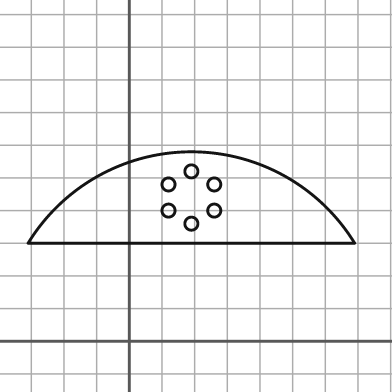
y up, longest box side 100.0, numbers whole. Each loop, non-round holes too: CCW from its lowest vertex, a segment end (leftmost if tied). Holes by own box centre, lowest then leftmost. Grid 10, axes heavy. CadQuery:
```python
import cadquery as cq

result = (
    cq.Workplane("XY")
    .moveTo(-31.0, 30.0)
    .lineTo(69.0, 30.0)
    .threePointArc((19.0, 58.0), (-31.0, 30.0))
    .close()
    .moveTo(19.0, 36.0)
    .circle(2.0)
    .moveTo(12.0, 40.0)
    .circle(2.0)
    .moveTo(26.0, 40.0)
    .circle(2.0)
    .moveTo(12.0, 48.0)
    .circle(2.0)
    .moveTo(26.0, 48.0)
    .circle(2.0)
    .moveTo(19.0, 52.0)
    .circle(2.0)
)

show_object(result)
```